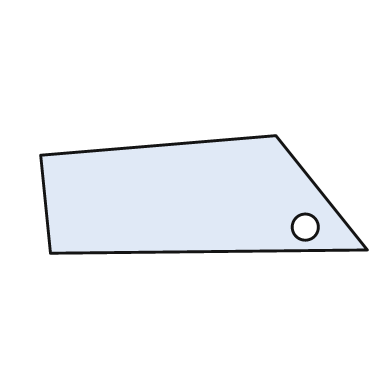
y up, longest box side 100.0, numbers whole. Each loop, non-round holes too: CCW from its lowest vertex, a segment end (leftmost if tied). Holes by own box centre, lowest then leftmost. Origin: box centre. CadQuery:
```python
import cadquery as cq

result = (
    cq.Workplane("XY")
    .moveTo(-47.0, -18.0)
    .lineTo(50.0, -17.0)
    .lineTo(22.0, 18.0)
    .lineTo(-50.0, 12.0)
    .close()
    .moveTo(31.0, -10.0)
    .circle(4.0)
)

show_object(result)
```